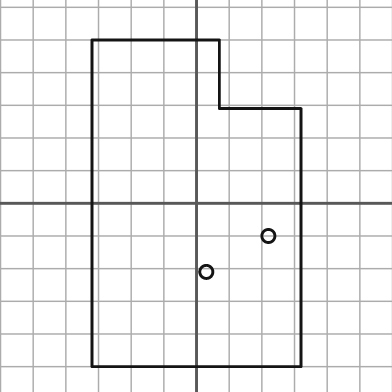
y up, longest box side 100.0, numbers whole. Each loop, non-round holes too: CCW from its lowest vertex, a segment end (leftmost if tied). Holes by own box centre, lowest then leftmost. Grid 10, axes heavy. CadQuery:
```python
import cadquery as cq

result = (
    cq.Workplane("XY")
    .moveTo(-32.0, -50.0)
    .lineTo(32.0, -50.0)
    .lineTo(32.0, 29.0)
    .lineTo(7.0, 29.0)
    .lineTo(7.0, 50.0)
    .lineTo(-32.0, 50.0)
    .close()
    .moveTo(3.0, -21.0)
    .circle(2.0)
    .moveTo(22.0, -10.0)
    .circle(2.0)
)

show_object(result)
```